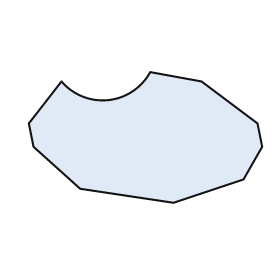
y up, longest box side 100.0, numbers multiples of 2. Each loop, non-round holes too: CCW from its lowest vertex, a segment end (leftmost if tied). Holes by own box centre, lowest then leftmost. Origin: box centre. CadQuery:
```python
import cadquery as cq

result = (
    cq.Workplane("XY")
    .moveTo(12.0, -28.0)
    .lineTo(42.0, -18.0)
    .lineTo(50.0, -4.0)
    .lineTo(48.0, 6.0)
    .lineTo(24.0, 24.0)
    .lineTo(2.0, 28.0)
    .threePointArc((-16.0, 16.0), (-36.0, 24.0))
    .lineTo(-50.0, 6.0)
    .lineTo(-48.0, -4.0)
    .lineTo(-28.0, -22.0)
    .close()
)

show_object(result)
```